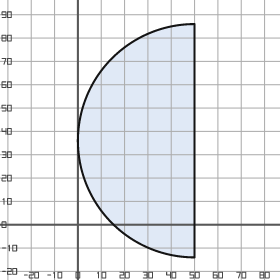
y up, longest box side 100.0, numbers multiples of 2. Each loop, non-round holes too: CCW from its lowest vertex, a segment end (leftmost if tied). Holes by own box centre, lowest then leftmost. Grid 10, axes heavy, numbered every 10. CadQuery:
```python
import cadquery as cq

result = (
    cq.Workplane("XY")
    .moveTo(50.0, -14.0)
    .lineTo(50.0, 86.0)
    .threePointArc((0.0, 36.0), (50.0, -14.0))
    .close()
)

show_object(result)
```